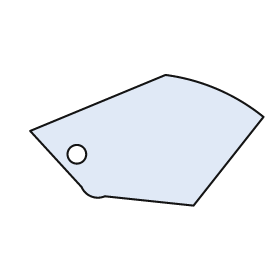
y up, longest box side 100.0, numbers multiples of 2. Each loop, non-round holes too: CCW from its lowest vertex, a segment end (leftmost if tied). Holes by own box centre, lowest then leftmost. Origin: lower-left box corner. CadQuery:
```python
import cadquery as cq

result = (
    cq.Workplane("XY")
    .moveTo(70.0, 0.0)
    .lineTo(100.0, 38.0)
    .threePointArc((80.0, 50.0), (58.0, 56.0))
    .lineTo(0.0, 32.0)
    .lineTo(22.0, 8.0)
    .threePointArc((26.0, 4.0), (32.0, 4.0))
    .close()
    .moveTo(20.0, 22.0)
    .circle(4.0)
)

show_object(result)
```